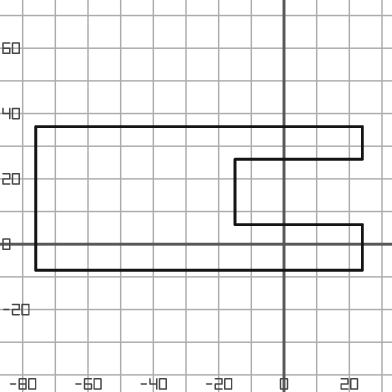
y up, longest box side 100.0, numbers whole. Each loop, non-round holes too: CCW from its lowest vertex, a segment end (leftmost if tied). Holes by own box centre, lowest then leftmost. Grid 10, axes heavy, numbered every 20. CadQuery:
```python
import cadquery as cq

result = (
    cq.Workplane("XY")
    .moveTo(-76.0, -8.0)
    .lineTo(24.0, -8.0)
    .lineTo(24.0, 6.0)
    .lineTo(-15.0, 6.0)
    .lineTo(-15.0, 26.0)
    .lineTo(24.0, 26.0)
    .lineTo(24.0, 36.0)
    .lineTo(-76.0, 36.0)
    .close()
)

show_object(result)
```